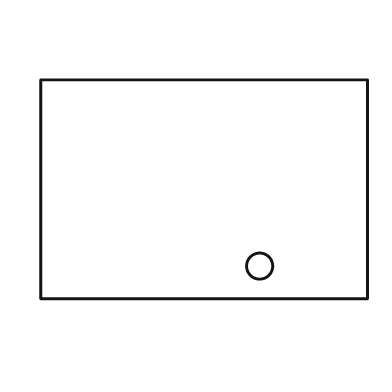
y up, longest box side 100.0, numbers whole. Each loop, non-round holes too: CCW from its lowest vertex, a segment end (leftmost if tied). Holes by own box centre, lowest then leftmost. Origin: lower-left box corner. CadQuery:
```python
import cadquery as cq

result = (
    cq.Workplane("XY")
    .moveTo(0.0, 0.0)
    .lineTo(100.0, 0.0)
    .lineTo(100.0, 67.0)
    .lineTo(0.0, 67.0)
    .close()
    .moveTo(67.0, 10.0)
    .circle(4.0)
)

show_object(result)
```